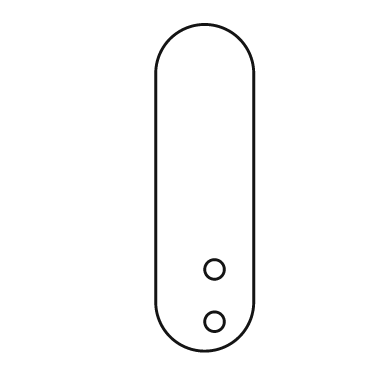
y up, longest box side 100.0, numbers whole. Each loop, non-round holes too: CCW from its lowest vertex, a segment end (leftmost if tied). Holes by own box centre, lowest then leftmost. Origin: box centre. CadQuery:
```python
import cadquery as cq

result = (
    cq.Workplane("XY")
    .moveTo(-15.0, -35.0)
    .threePointArc((0.0, -50.0), (15.0, -35.0))
    .lineTo(15.0, 35.0)
    .threePointArc((0.0, 50.0), (-15.0, 35.0))
    .close()
    .moveTo(3.0, -41.0)
    .circle(3.0)
    .moveTo(3.0, -25.0)
    .circle(3.0)
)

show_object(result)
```